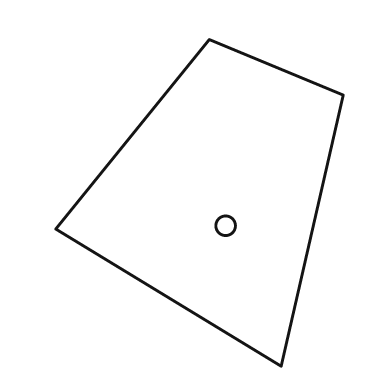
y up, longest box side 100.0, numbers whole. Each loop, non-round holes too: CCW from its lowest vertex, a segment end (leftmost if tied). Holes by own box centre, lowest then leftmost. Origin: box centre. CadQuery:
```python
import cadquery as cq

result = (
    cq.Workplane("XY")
    .moveTo(25.0, -50.0)
    .lineTo(44.0, 33.0)
    .lineTo(3.0, 50.0)
    .lineTo(-44.0, -8.0)
    .close()
    .moveTo(8.0, -7.0)
    .circle(3.0)
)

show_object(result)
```